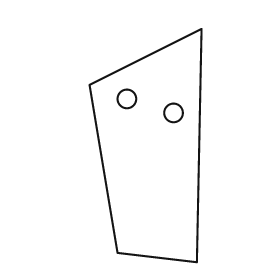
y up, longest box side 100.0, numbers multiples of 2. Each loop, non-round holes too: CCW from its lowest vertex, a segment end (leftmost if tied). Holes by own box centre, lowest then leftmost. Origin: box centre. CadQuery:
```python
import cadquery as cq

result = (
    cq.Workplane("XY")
    .moveTo(22.0, -50.0)
    .lineTo(24.0, 50.0)
    .lineTo(-24.0, 26.0)
    .lineTo(-12.0, -46.0)
    .close()
    .moveTo(12.0, 14.0)
    .circle(4.0)
    .moveTo(-8.0, 20.0)
    .circle(4.0)
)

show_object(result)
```